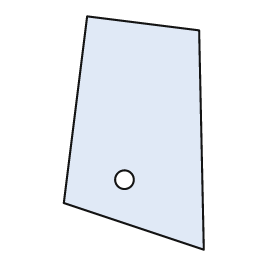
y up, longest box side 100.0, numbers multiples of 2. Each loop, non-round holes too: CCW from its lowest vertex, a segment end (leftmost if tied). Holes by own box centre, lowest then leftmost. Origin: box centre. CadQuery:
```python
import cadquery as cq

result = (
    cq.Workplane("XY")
    .moveTo(30.0, -50.0)
    .lineTo(28.0, 44.0)
    .lineTo(-20.0, 50.0)
    .lineTo(-30.0, -30.0)
    .close()
    .moveTo(-4.0, -20.0)
    .circle(4.0)
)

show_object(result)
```